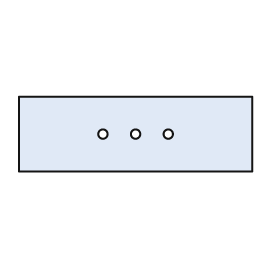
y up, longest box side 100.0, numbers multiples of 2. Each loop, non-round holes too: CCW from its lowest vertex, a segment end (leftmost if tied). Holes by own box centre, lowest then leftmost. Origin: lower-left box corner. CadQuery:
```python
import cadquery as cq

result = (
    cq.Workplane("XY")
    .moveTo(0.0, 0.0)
    .lineTo(100.0, 0.0)
    .lineTo(100.0, 32.0)
    .lineTo(0.0, 32.0)
    .close()
    .moveTo(36.0, 16.0)
    .circle(2.0)
    .moveTo(50.0, 16.0)
    .circle(2.0)
    .moveTo(64.0, 16.0)
    .circle(2.0)
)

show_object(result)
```